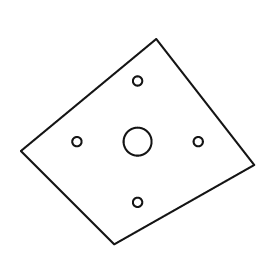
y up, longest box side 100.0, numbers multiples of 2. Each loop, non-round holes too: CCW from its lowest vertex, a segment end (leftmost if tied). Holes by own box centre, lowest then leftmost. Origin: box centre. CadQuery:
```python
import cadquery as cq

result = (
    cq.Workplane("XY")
    .moveTo(-10.0, -44.0)
    .lineTo(50.0, -10.0)
    .lineTo(8.0, 44.0)
    .lineTo(-50.0, -4.0)
    .close()
    .moveTo(0.0, -26.0)
    .circle(2.0)
    .moveTo(-26.0, 0.0)
    .circle(2.0)
    .moveTo(0.0, 0.0)
    .circle(6.0)
    .moveTo(26.0, 0.0)
    .circle(2.0)
    .moveTo(0.0, 26.0)
    .circle(2.0)
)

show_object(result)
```